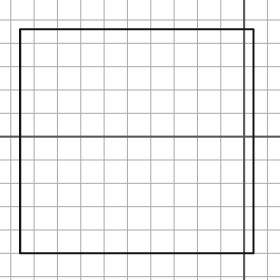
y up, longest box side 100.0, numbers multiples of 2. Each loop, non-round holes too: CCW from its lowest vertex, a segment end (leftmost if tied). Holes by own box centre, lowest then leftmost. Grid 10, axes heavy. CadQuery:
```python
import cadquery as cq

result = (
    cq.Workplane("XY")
    .moveTo(-96.0, -50.0)
    .lineTo(4.0, -50.0)
    .lineTo(4.0, 46.0)
    .lineTo(-96.0, 46.0)
    .close()
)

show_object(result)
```